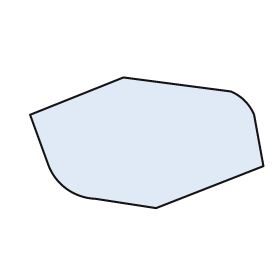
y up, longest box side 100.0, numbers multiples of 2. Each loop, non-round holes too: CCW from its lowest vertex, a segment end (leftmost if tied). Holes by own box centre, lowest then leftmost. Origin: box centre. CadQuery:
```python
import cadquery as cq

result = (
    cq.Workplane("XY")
    .moveTo(4.0, -28.0)
    .lineTo(50.0, -10.0)
    .lineTo(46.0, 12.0)
    .threePointArc((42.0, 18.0), (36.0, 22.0))
    .lineTo(-10.0, 28.0)
    .lineTo(-50.0, 12.0)
    .lineTo(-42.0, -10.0)
    .threePointArc((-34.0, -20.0), (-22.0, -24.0))
    .close()
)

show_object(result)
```